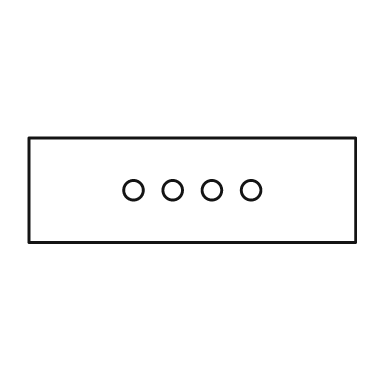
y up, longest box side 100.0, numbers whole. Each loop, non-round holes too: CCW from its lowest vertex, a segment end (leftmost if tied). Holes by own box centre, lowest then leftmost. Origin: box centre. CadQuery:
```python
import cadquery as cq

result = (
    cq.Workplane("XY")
    .moveTo(-50.0, -16.0)
    .lineTo(50.0, -16.0)
    .lineTo(50.0, 16.0)
    .lineTo(-50.0, 16.0)
    .close()
    .moveTo(-18.0, 0.0)
    .circle(3.0)
    .moveTo(-6.0, 0.0)
    .circle(3.0)
    .moveTo(6.0, 0.0)
    .circle(3.0)
    .moveTo(18.0, 0.0)
    .circle(3.0)
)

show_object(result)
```